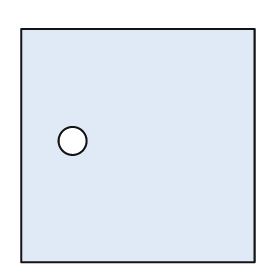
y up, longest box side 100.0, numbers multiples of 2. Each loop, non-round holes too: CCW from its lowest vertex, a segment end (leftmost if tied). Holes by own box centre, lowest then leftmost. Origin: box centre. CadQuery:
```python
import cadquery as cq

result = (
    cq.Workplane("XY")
    .moveTo(-50.0, -50.0)
    .lineTo(50.0, -50.0)
    .lineTo(50.0, 50.0)
    .lineTo(-50.0, 50.0)
    .close()
    .moveTo(-28.0, 2.0)
    .circle(6.0)
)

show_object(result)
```